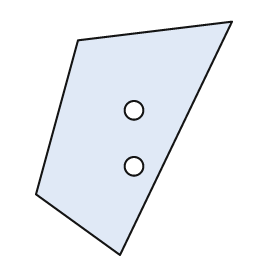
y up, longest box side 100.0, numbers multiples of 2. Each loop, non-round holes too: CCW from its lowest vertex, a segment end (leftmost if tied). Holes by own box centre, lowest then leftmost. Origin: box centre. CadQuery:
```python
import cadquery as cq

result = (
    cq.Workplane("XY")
    .moveTo(-6.0, -50.0)
    .lineTo(42.0, 50.0)
    .lineTo(-24.0, 42.0)
    .lineTo(-42.0, -24.0)
    .close()
    .moveTo(0.0, -12.0)
    .circle(4.0)
    .moveTo(0.0, 12.0)
    .circle(4.0)
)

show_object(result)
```